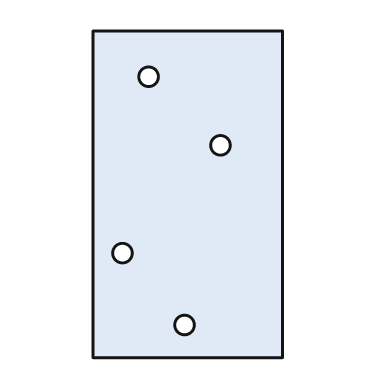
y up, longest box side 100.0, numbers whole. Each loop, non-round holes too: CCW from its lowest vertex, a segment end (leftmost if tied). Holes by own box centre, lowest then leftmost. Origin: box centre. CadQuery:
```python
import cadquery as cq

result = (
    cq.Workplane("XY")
    .moveTo(-29.0, -50.0)
    .lineTo(29.0, -50.0)
    .lineTo(29.0, 50.0)
    .lineTo(-29.0, 50.0)
    .close()
    .moveTo(-1.0, -40.0)
    .circle(3.0)
    .moveTo(-20.0, -18.0)
    .circle(3.0)
    .moveTo(10.0, 15.0)
    .circle(3.0)
    .moveTo(-12.0, 36.0)
    .circle(3.0)
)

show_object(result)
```